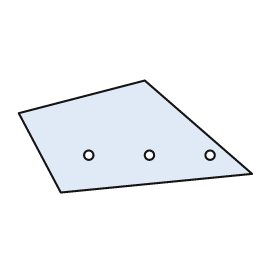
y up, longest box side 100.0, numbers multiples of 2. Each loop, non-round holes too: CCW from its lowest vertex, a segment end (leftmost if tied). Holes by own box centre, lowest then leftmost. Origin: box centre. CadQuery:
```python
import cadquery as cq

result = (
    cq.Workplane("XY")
    .moveTo(-32.0, -24.0)
    .lineTo(50.0, -16.0)
    .lineTo(4.0, 24.0)
    .lineTo(-50.0, 10.0)
    .close()
    .moveTo(-20.0, -8.0)
    .circle(2.0)
    .moveTo(6.0, -8.0)
    .circle(2.0)
    .moveTo(32.0, -8.0)
    .circle(2.0)
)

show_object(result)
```